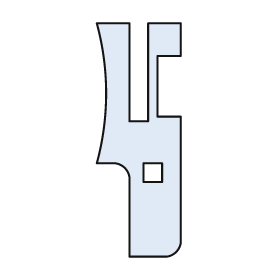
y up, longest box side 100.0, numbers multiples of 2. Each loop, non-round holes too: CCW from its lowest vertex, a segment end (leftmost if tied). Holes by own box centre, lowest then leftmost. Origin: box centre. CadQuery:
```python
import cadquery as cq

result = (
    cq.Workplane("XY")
    .moveTo(-4.0, -50.0)
    .lineTo(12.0, -50.0)
    .threePointArc((16.0, -48.0), (18.0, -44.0))
    .lineTo(18.0, 10.0)
    .lineTo(8.0, 10.0)
    .lineTo(8.0, 36.0)
    .lineTo(18.0, 36.0)
    .lineTo(18.0, 50.0)
    .lineTo(4.0, 50.0)
    .lineTo(4.0, 8.0)
    .lineTo(-4.0, 8.0)
    .lineTo(-4.0, 50.0)
    .lineTo(-18.0, 50.0)
    .threePointArc((-14.0, 20.0), (-18.0, -10.0))
    .lineTo(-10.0, -10.0)
    .threePointArc((-6.0, -12.0), (-4.0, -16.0))
    .close()
    .moveTo(2.0, -18.0)
    .lineTo(10.0, -18.0)
    .lineTo(10.0, -10.0)
    .lineTo(2.0, -10.0)
    .close()
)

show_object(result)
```